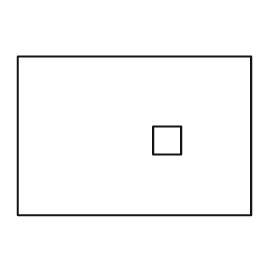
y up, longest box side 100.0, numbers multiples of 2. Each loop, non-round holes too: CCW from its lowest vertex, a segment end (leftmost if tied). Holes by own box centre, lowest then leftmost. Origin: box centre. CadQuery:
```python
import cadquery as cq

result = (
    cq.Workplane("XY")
    .moveTo(-50.0, -34.0)
    .lineTo(50.0, -34.0)
    .lineTo(50.0, 34.0)
    .lineTo(-50.0, 34.0)
    .close()
    .moveTo(8.0, -8.0)
    .lineTo(20.0, -8.0)
    .lineTo(20.0, 4.0)
    .lineTo(8.0, 4.0)
    .close()
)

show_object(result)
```